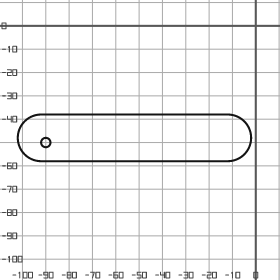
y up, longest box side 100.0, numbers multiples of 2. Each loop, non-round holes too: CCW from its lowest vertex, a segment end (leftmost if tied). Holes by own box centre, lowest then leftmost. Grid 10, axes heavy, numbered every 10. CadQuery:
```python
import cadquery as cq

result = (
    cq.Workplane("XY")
    .moveTo(-92.0, -58.0)
    .lineTo(-12.0, -58.0)
    .threePointArc((-2.0, -48.0), (-12.0, -38.0))
    .lineTo(-92.0, -38.0)
    .threePointArc((-102.0, -48.0), (-92.0, -58.0))
    .close()
    .moveTo(-90.0, -50.0)
    .circle(2.0)
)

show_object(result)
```